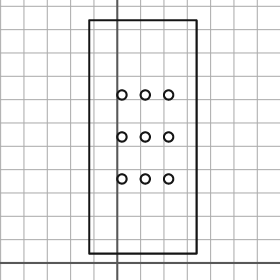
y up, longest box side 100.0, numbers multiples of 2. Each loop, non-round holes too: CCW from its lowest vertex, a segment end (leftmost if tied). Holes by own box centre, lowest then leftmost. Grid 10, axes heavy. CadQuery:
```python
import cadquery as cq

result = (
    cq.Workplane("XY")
    .moveTo(-12.0, 4.0)
    .lineTo(34.0, 4.0)
    .lineTo(34.0, 104.0)
    .lineTo(-12.0, 104.0)
    .close()
    .moveTo(2.0, 36.0)
    .circle(2.0)
    .moveTo(12.0, 36.0)
    .circle(2.0)
    .moveTo(22.0, 36.0)
    .circle(2.0)
    .moveTo(2.0, 54.0)
    .circle(2.0)
    .moveTo(12.0, 54.0)
    .circle(2.0)
    .moveTo(22.0, 54.0)
    .circle(2.0)
    .moveTo(2.0, 72.0)
    .circle(2.0)
    .moveTo(12.0, 72.0)
    .circle(2.0)
    .moveTo(22.0, 72.0)
    .circle(2.0)
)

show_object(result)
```